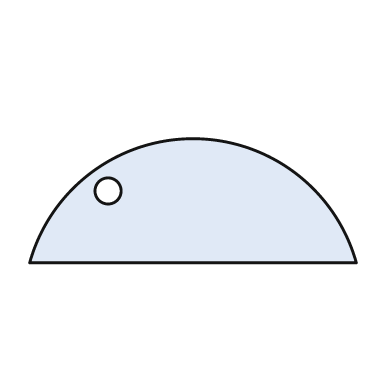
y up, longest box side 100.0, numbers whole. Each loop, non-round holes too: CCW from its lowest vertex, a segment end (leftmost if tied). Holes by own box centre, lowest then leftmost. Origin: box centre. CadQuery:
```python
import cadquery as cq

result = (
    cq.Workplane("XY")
    .moveTo(-50.0, -19.0)
    .lineTo(50.0, -19.0)
    .threePointArc((0.0, 19.0), (-50.0, -19.0))
    .close()
    .moveTo(-26.0, 3.0)
    .circle(4.0)
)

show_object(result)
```